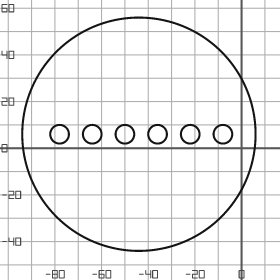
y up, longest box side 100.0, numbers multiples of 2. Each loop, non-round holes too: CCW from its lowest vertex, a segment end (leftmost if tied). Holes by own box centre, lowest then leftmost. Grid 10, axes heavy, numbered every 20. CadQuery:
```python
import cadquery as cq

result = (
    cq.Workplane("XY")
    .moveTo(-44.0, 6.0)
    .circle(50.0)
    .moveTo(-78.0, 6.0)
    .circle(4.0)
    .moveTo(-64.0, 6.0)
    .circle(4.0)
    .moveTo(-50.0, 6.0)
    .circle(4.0)
    .moveTo(-36.0, 6.0)
    .circle(4.0)
    .moveTo(-22.0, 6.0)
    .circle(4.0)
    .moveTo(-8.0, 6.0)
    .circle(4.0)
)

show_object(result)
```